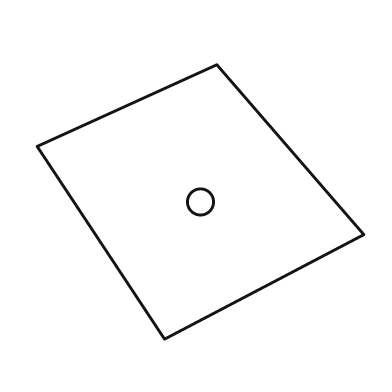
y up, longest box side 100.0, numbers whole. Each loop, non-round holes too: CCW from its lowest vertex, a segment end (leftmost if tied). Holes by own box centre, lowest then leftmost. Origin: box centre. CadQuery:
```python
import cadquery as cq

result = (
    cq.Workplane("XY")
    .moveTo(-11.0, -42.0)
    .lineTo(50.0, -10.0)
    .lineTo(5.0, 42.0)
    .lineTo(-50.0, 17.0)
    .close()
    .moveTo(0.0, 0.0)
    .circle(4.0)
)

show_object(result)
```